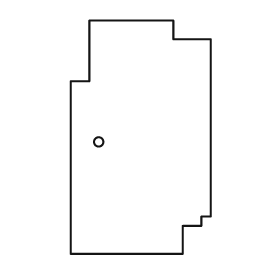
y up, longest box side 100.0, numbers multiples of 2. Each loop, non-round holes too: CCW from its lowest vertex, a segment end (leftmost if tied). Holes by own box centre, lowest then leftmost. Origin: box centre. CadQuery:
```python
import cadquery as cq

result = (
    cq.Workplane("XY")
    .moveTo(-30.0, -50.0)
    .lineTo(18.0, -50.0)
    .lineTo(18.0, -38.0)
    .lineTo(26.0, -38.0)
    .lineTo(26.0, -34.0)
    .lineTo(30.0, -34.0)
    .lineTo(30.0, 42.0)
    .lineTo(14.0, 42.0)
    .lineTo(14.0, 50.0)
    .lineTo(-22.0, 50.0)
    .lineTo(-22.0, 24.0)
    .lineTo(-30.0, 24.0)
    .close()
    .moveTo(-18.0, -2.0)
    .circle(2.0)
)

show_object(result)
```